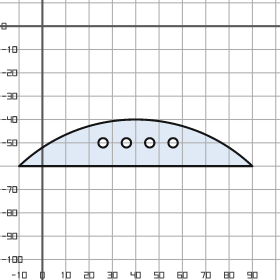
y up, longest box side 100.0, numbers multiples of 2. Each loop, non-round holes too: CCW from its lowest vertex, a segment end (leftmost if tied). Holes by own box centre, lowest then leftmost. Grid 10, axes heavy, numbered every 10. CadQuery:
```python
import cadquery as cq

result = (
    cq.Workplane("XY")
    .moveTo(-10.0, -60.0)
    .lineTo(90.0, -60.0)
    .threePointArc((40.0, -40.0), (-10.0, -60.0))
    .close()
    .moveTo(26.0, -50.0)
    .circle(2.0)
    .moveTo(36.0, -50.0)
    .circle(2.0)
    .moveTo(46.0, -50.0)
    .circle(2.0)
    .moveTo(56.0, -50.0)
    .circle(2.0)
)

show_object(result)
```